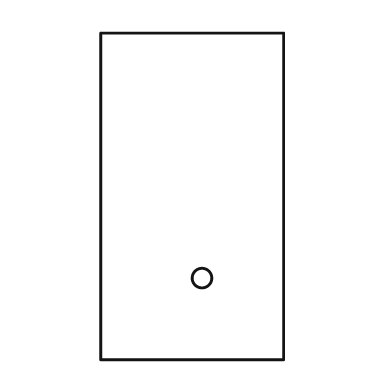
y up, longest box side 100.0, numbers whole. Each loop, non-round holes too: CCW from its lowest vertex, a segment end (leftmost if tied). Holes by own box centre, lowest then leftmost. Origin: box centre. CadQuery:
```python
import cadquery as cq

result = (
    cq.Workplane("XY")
    .moveTo(-28.0, -50.0)
    .lineTo(28.0, -50.0)
    .lineTo(28.0, 50.0)
    .lineTo(-28.0, 50.0)
    .close()
    .moveTo(3.0, -25.0)
    .circle(3.0)
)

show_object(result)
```